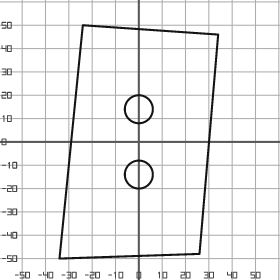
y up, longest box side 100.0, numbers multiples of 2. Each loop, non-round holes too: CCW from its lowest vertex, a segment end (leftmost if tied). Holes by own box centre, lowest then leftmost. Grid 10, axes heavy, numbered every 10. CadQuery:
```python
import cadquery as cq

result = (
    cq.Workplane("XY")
    .moveTo(-34.0, -50.0)
    .lineTo(26.0, -48.0)
    .lineTo(34.0, 46.0)
    .lineTo(-24.0, 50.0)
    .close()
    .moveTo(0.0, -14.0)
    .circle(6.0)
    .moveTo(0.0, 14.0)
    .circle(6.0)
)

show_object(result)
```